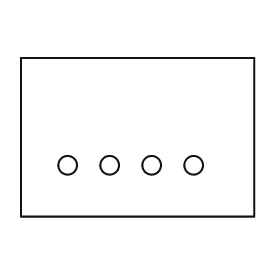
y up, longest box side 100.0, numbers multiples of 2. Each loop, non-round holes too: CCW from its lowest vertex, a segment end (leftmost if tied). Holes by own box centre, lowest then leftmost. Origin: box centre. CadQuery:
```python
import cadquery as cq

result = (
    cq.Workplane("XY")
    .moveTo(-50.0, -34.0)
    .lineTo(50.0, -34.0)
    .lineTo(50.0, 34.0)
    .lineTo(-50.0, 34.0)
    .close()
    .moveTo(-30.0, -12.0)
    .circle(4.0)
    .moveTo(-12.0, -12.0)
    .circle(4.0)
    .moveTo(6.0, -12.0)
    .circle(4.0)
    .moveTo(24.0, -12.0)
    .circle(4.0)
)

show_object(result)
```